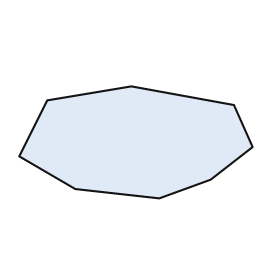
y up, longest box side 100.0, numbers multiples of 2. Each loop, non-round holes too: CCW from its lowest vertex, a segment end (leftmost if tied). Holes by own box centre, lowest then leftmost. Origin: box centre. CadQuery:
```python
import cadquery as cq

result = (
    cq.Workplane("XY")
    .moveTo(10.0, -24.0)
    .lineTo(32.0, -16.0)
    .lineTo(50.0, -2.0)
    .lineTo(42.0, 16.0)
    .lineTo(-2.0, 24.0)
    .lineTo(-38.0, 18.0)
    .lineTo(-50.0, -6.0)
    .lineTo(-26.0, -20.0)
    .close()
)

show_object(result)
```